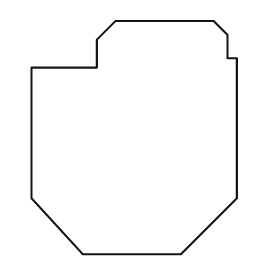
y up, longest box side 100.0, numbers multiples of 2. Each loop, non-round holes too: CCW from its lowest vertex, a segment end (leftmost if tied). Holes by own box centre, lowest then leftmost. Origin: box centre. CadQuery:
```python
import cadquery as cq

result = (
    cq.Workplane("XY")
    .moveTo(-22.0, -50.0)
    .lineTo(20.0, -50.0)
    .lineTo(44.0, -26.0)
    .lineTo(44.0, 34.0)
    .lineTo(40.0, 34.0)
    .lineTo(40.0, 44.0)
    .lineTo(34.0, 50.0)
    .lineTo(-8.0, 50.0)
    .lineTo(-16.0, 42.0)
    .lineTo(-16.0, 30.0)
    .lineTo(-44.0, 30.0)
    .lineTo(-44.0, -26.0)
    .close()
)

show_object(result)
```